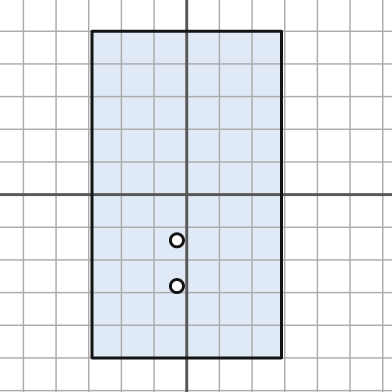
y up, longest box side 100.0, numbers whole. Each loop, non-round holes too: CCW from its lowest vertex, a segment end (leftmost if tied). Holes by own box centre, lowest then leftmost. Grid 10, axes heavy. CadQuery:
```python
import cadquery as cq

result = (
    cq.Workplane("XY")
    .moveTo(-29.0, -50.0)
    .lineTo(29.0, -50.0)
    .lineTo(29.0, 50.0)
    .lineTo(-29.0, 50.0)
    .close()
    .moveTo(-3.0, -28.0)
    .circle(2.0)
    .moveTo(-3.0, -14.0)
    .circle(2.0)
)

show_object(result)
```